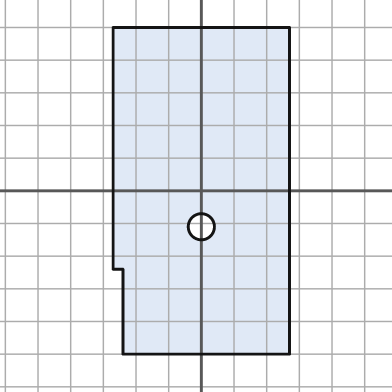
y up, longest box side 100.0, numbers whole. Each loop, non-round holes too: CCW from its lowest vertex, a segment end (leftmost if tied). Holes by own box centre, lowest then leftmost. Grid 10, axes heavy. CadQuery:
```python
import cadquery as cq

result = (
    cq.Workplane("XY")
    .moveTo(-24.0, -50.0)
    .lineTo(27.0, -50.0)
    .lineTo(27.0, 50.0)
    .lineTo(-27.0, 50.0)
    .lineTo(-27.0, -24.0)
    .lineTo(-24.0, -24.0)
    .close()
    .moveTo(0.0, -11.0)
    .circle(4.0)
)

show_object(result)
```